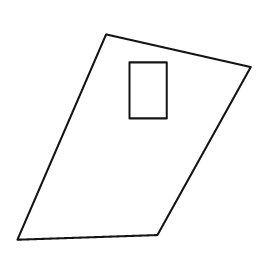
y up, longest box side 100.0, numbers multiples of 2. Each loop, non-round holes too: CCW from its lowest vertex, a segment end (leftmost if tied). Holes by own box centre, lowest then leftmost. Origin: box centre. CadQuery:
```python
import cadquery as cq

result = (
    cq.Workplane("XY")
    .moveTo(-50.0, -44.0)
    .lineTo(10.0, -42.0)
    .lineTo(50.0, 30.0)
    .lineTo(-12.0, 44.0)
    .close()
    .moveTo(-2.0, 8.0)
    .lineTo(14.0, 8.0)
    .lineTo(14.0, 32.0)
    .lineTo(-2.0, 32.0)
    .close()
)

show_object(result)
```